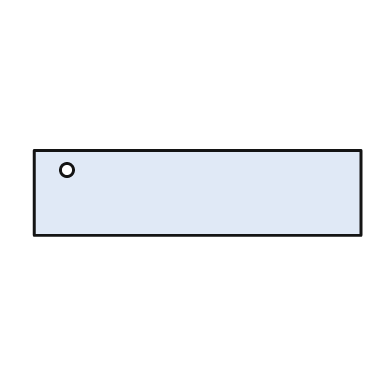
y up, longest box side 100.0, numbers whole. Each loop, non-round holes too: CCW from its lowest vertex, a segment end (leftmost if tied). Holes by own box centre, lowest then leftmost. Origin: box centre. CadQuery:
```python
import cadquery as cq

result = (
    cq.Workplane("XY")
    .moveTo(-50.0, -13.0)
    .lineTo(50.0, -13.0)
    .lineTo(50.0, 13.0)
    .lineTo(-50.0, 13.0)
    .close()
    .moveTo(-40.0, 7.0)
    .circle(2.0)
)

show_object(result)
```